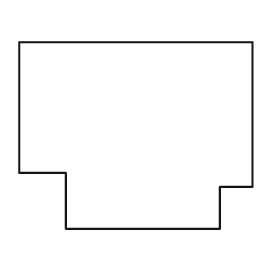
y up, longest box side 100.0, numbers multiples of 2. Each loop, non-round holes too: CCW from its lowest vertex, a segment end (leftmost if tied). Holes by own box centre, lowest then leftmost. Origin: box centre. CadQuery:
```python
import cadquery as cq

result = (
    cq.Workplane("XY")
    .moveTo(-30.0, -40.0)
    .lineTo(36.0, -40.0)
    .lineTo(36.0, -22.0)
    .lineTo(50.0, -22.0)
    .lineTo(50.0, 40.0)
    .lineTo(-50.0, 40.0)
    .lineTo(-50.0, -16.0)
    .lineTo(-30.0, -16.0)
    .close()
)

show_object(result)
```